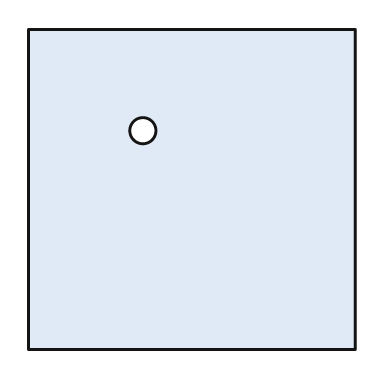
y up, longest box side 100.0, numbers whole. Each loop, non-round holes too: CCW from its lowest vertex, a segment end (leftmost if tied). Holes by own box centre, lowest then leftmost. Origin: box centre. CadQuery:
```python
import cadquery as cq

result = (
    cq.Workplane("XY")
    .moveTo(-50.0, -49.0)
    .lineTo(50.0, -49.0)
    .lineTo(50.0, 49.0)
    .lineTo(-50.0, 49.0)
    .close()
    .moveTo(-15.0, 18.0)
    .circle(4.0)
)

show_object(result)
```